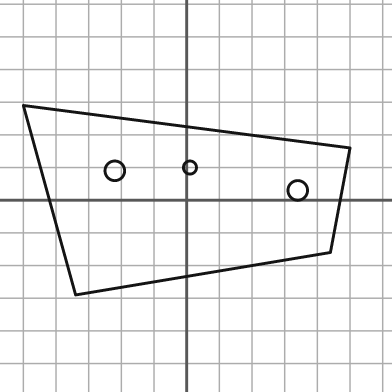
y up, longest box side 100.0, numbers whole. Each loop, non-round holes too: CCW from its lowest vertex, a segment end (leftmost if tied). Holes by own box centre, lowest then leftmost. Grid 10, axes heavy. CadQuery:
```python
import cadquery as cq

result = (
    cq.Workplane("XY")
    .moveTo(-34.0, -29.0)
    .lineTo(44.0, -16.0)
    .lineTo(50.0, 16.0)
    .lineTo(-50.0, 29.0)
    .close()
    .moveTo(34.0, 3.0)
    .circle(3.0)
    .moveTo(-22.0, 9.0)
    .circle(3.0)
    .moveTo(1.0, 10.0)
    .circle(2.0)
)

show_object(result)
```